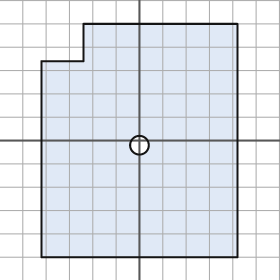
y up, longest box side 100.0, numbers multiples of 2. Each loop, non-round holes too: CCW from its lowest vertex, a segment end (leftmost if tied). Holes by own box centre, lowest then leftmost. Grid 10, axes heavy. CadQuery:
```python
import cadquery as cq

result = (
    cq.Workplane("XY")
    .moveTo(-42.0, -50.0)
    .lineTo(42.0, -50.0)
    .lineTo(42.0, 50.0)
    .lineTo(-24.0, 50.0)
    .lineTo(-24.0, 34.0)
    .lineTo(-42.0, 34.0)
    .close()
    .moveTo(0.0, -2.0)
    .circle(4.0)
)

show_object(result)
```